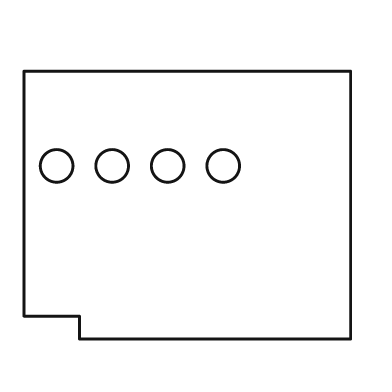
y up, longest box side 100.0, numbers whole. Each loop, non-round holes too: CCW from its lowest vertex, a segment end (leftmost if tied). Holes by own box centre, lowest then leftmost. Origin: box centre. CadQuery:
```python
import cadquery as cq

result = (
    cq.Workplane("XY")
    .moveTo(-33.0, -41.0)
    .lineTo(50.0, -41.0)
    .lineTo(50.0, 41.0)
    .lineTo(-50.0, 41.0)
    .lineTo(-50.0, -34.0)
    .lineTo(-33.0, -34.0)
    .close()
    .moveTo(-40.0, 12.0)
    .circle(5.0)
    .moveTo(-23.0, 12.0)
    .circle(5.0)
    .moveTo(-6.0, 12.0)
    .circle(5.0)
    .moveTo(11.0, 12.0)
    .circle(5.0)
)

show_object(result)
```